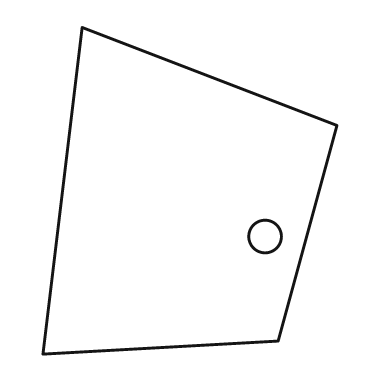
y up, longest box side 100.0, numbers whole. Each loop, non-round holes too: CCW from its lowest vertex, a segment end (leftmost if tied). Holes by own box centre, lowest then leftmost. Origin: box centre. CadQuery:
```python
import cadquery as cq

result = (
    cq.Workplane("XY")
    .moveTo(-45.0, -50.0)
    .lineTo(27.0, -46.0)
    .lineTo(45.0, 20.0)
    .lineTo(-33.0, 50.0)
    .close()
    .moveTo(23.0, -14.0)
    .circle(5.0)
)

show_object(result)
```